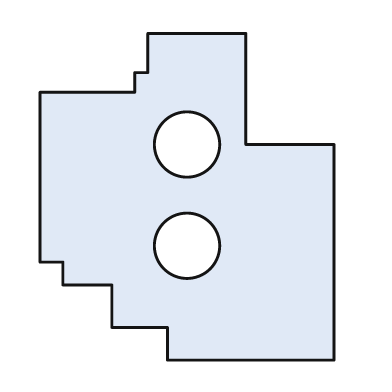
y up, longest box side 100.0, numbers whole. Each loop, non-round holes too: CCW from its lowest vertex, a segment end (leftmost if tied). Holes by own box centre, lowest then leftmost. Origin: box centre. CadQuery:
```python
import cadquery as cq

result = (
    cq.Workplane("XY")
    .moveTo(-6.0, -50.0)
    .lineTo(45.0, -50.0)
    .lineTo(45.0, 16.0)
    .lineTo(18.0, 16.0)
    .lineTo(18.0, 50.0)
    .lineTo(-12.0, 50.0)
    .lineTo(-12.0, 38.0)
    .lineTo(-16.0, 38.0)
    .lineTo(-16.0, 32.0)
    .lineTo(-45.0, 32.0)
    .lineTo(-45.0, -20.0)
    .lineTo(-38.0, -20.0)
    .lineTo(-38.0, -27.0)
    .lineTo(-23.0, -27.0)
    .lineTo(-23.0, -40.0)
    .lineTo(-6.0, -40.0)
    .close()
    .moveTo(0.0, -15.0)
    .circle(10.0)
    .moveTo(0.0, 16.0)
    .circle(10.0)
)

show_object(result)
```